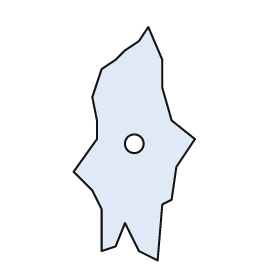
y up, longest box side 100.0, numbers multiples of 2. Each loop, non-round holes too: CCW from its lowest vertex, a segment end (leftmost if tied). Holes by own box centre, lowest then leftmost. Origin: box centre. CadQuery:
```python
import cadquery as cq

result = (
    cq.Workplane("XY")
    .moveTo(10.0, -50.0)
    .lineTo(12.0, -26.0)
    .lineTo(16.0, -24.0)
    .lineTo(18.0, -10.0)
    .lineTo(26.0, 2.0)
    .lineTo(16.0, 10.0)
    .lineTo(12.0, 24.0)
    .lineTo(12.0, 36.0)
    .lineTo(6.0, 50.0)
    .lineTo(2.0, 44.0)
    .lineTo(-4.0, 40.0)
    .lineTo(-8.0, 36.0)
    .lineTo(-14.0, 32.0)
    .lineTo(-18.0, 20.0)
    .lineTo(-16.0, 10.0)
    .lineTo(-16.0, 2.0)
    .lineTo(-26.0, -12.0)
    .lineTo(-18.0, -20.0)
    .lineTo(-14.0, -28.0)
    .lineTo(-14.0, -46.0)
    .lineTo(-8.0, -44.0)
    .lineTo(-4.0, -34.0)
    .lineTo(2.0, -46.0)
    .close()
    .moveTo(0.0, 0.0)
    .circle(4.0)
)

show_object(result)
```